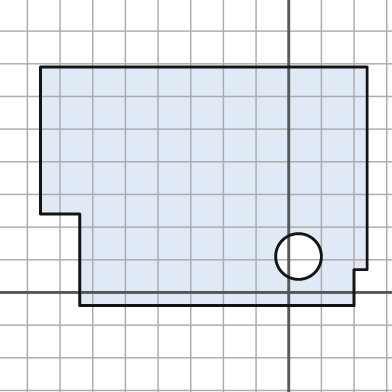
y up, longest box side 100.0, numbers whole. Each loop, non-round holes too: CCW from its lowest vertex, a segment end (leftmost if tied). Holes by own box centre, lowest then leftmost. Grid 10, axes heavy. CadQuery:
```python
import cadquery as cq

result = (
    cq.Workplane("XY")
    .moveTo(-64.0, -4.0)
    .lineTo(20.0, -4.0)
    .lineTo(20.0, 7.0)
    .lineTo(24.0, 7.0)
    .lineTo(24.0, 69.0)
    .lineTo(-76.0, 69.0)
    .lineTo(-76.0, 24.0)
    .lineTo(-64.0, 24.0)
    .close()
    .moveTo(3.0, 11.0)
    .circle(7.0)
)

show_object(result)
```